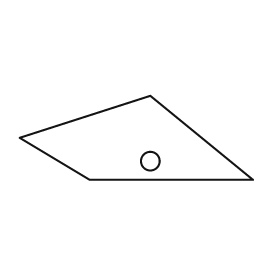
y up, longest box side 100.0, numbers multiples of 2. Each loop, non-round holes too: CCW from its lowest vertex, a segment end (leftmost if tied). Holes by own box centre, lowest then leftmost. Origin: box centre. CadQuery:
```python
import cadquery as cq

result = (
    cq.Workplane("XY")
    .moveTo(-20.0, -18.0)
    .lineTo(50.0, -18.0)
    .lineTo(6.0, 18.0)
    .lineTo(-50.0, 0.0)
    .close()
    .moveTo(6.0, -10.0)
    .circle(4.0)
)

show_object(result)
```